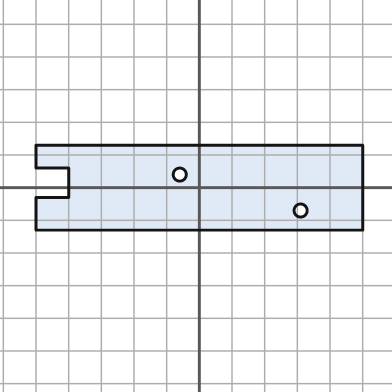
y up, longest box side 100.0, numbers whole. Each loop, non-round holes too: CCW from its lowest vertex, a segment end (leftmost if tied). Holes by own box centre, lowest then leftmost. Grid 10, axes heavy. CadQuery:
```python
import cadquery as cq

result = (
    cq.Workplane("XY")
    .moveTo(-50.0, -13.0)
    .lineTo(50.0, -13.0)
    .lineTo(50.0, 13.0)
    .lineTo(-50.0, 13.0)
    .lineTo(-50.0, 6.0)
    .lineTo(-40.0, 6.0)
    .lineTo(-40.0, -3.0)
    .lineTo(-50.0, -3.0)
    .close()
    .moveTo(31.0, -7.0)
    .circle(2.0)
    .moveTo(-6.0, 4.0)
    .circle(2.0)
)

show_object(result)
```